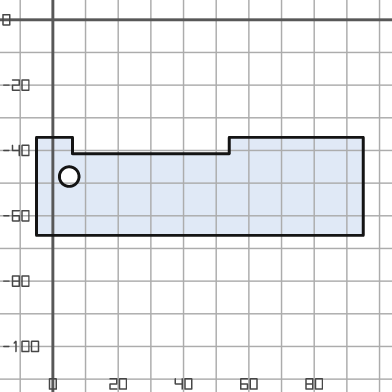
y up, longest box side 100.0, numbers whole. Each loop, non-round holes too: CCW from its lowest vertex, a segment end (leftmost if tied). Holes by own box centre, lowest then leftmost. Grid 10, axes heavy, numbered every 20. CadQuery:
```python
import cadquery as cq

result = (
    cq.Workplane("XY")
    .moveTo(-5.0, -66.0)
    .lineTo(95.0, -66.0)
    .lineTo(95.0, -36.0)
    .lineTo(54.0, -36.0)
    .lineTo(54.0, -41.0)
    .lineTo(6.0, -41.0)
    .lineTo(6.0, -36.0)
    .lineTo(-5.0, -36.0)
    .close()
    .moveTo(5.0, -48.0)
    .circle(3.0)
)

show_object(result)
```